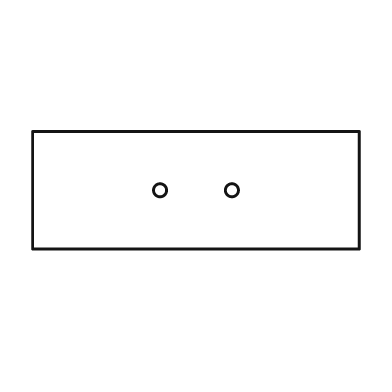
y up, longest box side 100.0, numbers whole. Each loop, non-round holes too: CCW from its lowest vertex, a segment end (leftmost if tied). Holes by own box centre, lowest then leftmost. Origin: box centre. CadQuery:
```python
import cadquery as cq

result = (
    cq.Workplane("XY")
    .moveTo(-50.0, -18.0)
    .lineTo(50.0, -18.0)
    .lineTo(50.0, 18.0)
    .lineTo(-50.0, 18.0)
    .close()
    .moveTo(-11.0, 0.0)
    .circle(2.0)
    .moveTo(11.0, 0.0)
    .circle(2.0)
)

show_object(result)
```